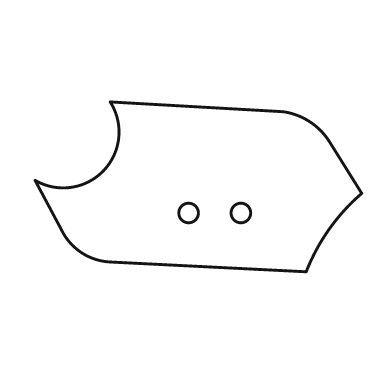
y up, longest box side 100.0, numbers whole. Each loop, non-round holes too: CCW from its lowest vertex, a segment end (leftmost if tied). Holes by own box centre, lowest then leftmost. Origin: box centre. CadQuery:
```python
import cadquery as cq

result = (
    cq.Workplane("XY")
    .moveTo(33.0, -26.0)
    .threePointArc((40.0, -13.0), (50.0, -2.0))
    .lineTo(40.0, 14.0)
    .threePointArc((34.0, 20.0), (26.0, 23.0))
    .lineTo(-27.0, 26.0)
    .threePointArc((-29.0, 5.0), (-50.0, 2.0))
    .lineTo(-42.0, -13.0)
    .threePointArc((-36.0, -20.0), (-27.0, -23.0))
    .close()
    .moveTo(-3.0, -8.0)
    .circle(3.0)
    .moveTo(13.0, -8.0)
    .circle(3.0)
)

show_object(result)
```